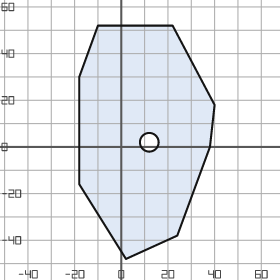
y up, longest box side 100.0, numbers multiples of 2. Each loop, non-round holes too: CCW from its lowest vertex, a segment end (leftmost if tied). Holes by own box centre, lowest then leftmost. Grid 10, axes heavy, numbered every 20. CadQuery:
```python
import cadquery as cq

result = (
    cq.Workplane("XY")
    .moveTo(2.0, -48.0)
    .lineTo(24.0, -38.0)
    .lineTo(38.0, 0.0)
    .lineTo(40.0, 18.0)
    .lineTo(22.0, 52.0)
    .lineTo(-10.0, 52.0)
    .lineTo(-18.0, 30.0)
    .lineTo(-18.0, -16.0)
    .close()
    .moveTo(12.0, 2.0)
    .circle(4.0)
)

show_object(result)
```